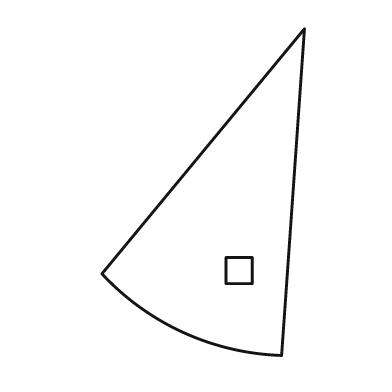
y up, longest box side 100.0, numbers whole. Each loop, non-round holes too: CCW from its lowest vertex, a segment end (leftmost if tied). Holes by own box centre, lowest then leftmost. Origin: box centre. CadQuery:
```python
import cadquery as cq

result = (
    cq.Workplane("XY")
    .moveTo(24.0, -50.0)
    .lineTo(31.0, 50.0)
    .lineTo(-31.0, -25.0)
    .threePointArc((-6.0, -43.0), (24.0, -50.0))
    .close()
    .moveTo(7.0, -28.0)
    .lineTo(15.0, -28.0)
    .lineTo(15.0, -20.0)
    .lineTo(7.0, -20.0)
    .close()
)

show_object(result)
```